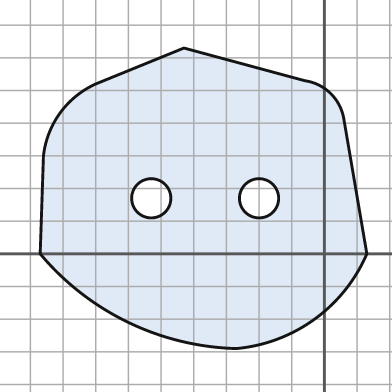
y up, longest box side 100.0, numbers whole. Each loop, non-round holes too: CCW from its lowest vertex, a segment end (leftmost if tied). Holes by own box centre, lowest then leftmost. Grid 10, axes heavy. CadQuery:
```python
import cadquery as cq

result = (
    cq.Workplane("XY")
    .moveTo(-27.0, -29.0)
    .threePointArc((-3.0, -20.0), (13.0, 0.0))
    .lineTo(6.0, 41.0)
    .threePointArc((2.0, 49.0), (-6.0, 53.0))
    .lineTo(-43.0, 63.0)
    .lineTo(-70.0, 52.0)
    .threePointArc((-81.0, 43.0), (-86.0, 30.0))
    .lineTo(-87.0, 0.0)
    .threePointArc((-60.0, -21.0), (-27.0, -29.0))
    .close()
    .moveTo(-53.0, 17.0)
    .circle(6.0)
    .moveTo(-20.0, 17.0)
    .circle(6.0)
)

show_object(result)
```